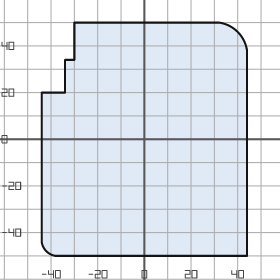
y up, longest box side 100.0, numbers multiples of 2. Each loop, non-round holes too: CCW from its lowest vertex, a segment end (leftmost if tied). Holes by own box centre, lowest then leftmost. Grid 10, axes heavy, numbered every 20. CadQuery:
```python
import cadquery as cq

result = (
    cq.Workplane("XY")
    .moveTo(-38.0, -50.0)
    .lineTo(44.0, -50.0)
    .lineTo(44.0, 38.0)
    .threePointArc((40.0, 46.0), (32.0, 50.0))
    .lineTo(-30.0, 50.0)
    .lineTo(-30.0, 34.0)
    .lineTo(-34.0, 34.0)
    .lineTo(-34.0, 20.0)
    .lineTo(-44.0, 20.0)
    .lineTo(-44.0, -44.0)
    .threePointArc((-42.0, -48.0), (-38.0, -50.0))
    .close()
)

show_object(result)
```